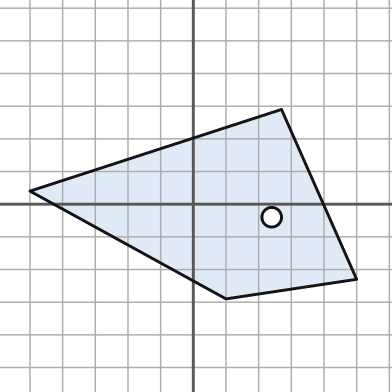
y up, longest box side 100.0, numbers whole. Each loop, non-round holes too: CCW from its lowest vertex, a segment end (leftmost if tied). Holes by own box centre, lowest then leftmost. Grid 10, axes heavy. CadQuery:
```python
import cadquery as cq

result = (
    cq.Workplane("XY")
    .moveTo(10.0, -29.0)
    .lineTo(50.0, -23.0)
    .lineTo(27.0, 29.0)
    .lineTo(-50.0, 4.0)
    .close()
    .moveTo(24.0, -4.0)
    .circle(3.0)
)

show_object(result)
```